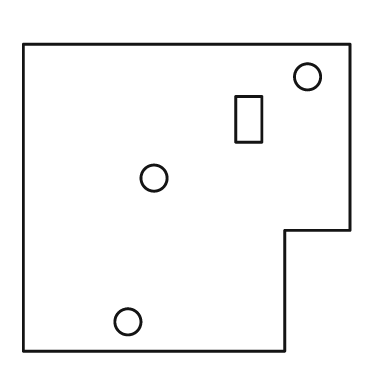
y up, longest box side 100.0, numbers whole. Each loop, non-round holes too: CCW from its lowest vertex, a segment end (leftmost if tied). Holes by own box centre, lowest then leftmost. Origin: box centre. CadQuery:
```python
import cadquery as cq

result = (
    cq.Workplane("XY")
    .moveTo(-50.0, -47.0)
    .lineTo(30.0, -47.0)
    .lineTo(30.0, -10.0)
    .lineTo(50.0, -10.0)
    .lineTo(50.0, 47.0)
    .lineTo(-50.0, 47.0)
    .close()
    .moveTo(-18.0, -38.0)
    .circle(4.0)
    .moveTo(-10.0, 6.0)
    .circle(4.0)
    .moveTo(15.0, 17.0)
    .lineTo(23.0, 17.0)
    .lineTo(23.0, 31.0)
    .lineTo(15.0, 31.0)
    .close()
    .moveTo(37.0, 37.0)
    .circle(4.0)
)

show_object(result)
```